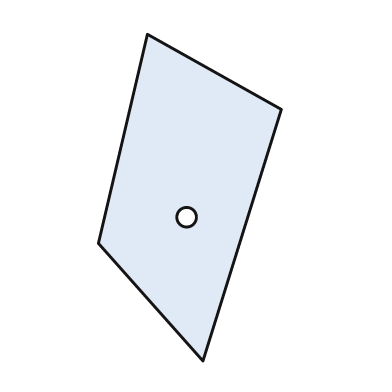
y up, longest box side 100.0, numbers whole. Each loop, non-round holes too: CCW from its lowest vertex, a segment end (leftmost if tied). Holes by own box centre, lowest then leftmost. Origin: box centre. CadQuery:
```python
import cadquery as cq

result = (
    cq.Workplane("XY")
    .moveTo(4.0, -50.0)
    .lineTo(28.0, 27.0)
    .lineTo(-13.0, 50.0)
    .lineTo(-28.0, -14.0)
    .close()
    .moveTo(-1.0, -6.0)
    .circle(3.0)
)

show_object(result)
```